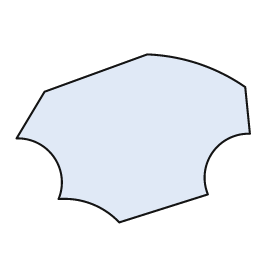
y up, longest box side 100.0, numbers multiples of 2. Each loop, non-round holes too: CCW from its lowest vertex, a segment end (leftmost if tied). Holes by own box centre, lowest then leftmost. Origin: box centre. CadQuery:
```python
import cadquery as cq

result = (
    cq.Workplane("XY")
    .moveTo(-6.0, -36.0)
    .lineTo(32.0, -24.0)
    .threePointArc((34.0, -6.0), (50.0, 2.0))
    .lineTo(48.0, 22.0)
    .threePointArc((28.0, 32.0), (6.0, 36.0))
    .lineTo(-38.0, 20.0)
    .lineTo(-50.0, 0.0)
    .threePointArc((-34.0, -8.0), (-32.0, -26.0))
    .threePointArc((-18.0, -28.0), (-6.0, -36.0))
    .close()
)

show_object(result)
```